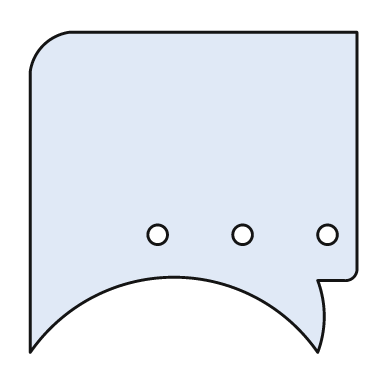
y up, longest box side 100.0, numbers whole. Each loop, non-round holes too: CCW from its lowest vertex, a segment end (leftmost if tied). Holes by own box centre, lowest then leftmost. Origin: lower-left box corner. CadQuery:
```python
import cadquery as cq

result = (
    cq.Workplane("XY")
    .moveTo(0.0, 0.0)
    .threePointArc((44.0, 23.0), (88.0, 0.0))
    .threePointArc((90.0, 11.0), (88.0, 22.0))
    .lineTo(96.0, 22.0)
    .threePointArc((99.0, 23.0), (100.0, 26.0))
    .lineTo(100.0, 98.0)
    .lineTo(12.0, 98.0)
    .threePointArc((4.0, 94.0), (0.0, 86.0))
    .close()
    .moveTo(39.0, 36.0)
    .circle(3.0)
    .moveTo(65.0, 36.0)
    .circle(3.0)
    .moveTo(91.0, 36.0)
    .circle(3.0)
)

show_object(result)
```